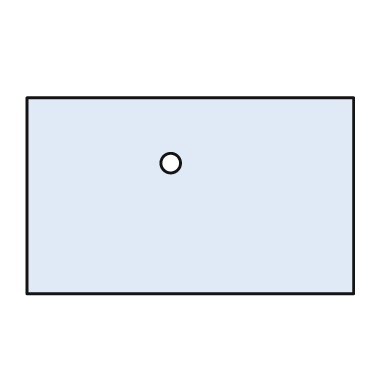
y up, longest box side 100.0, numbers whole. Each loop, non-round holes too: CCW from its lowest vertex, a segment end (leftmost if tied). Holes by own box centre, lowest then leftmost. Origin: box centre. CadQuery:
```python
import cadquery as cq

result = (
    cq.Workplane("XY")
    .moveTo(-50.0, -30.0)
    .lineTo(50.0, -30.0)
    .lineTo(50.0, 30.0)
    .lineTo(-50.0, 30.0)
    .close()
    .moveTo(-6.0, 10.0)
    .circle(3.0)
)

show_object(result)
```